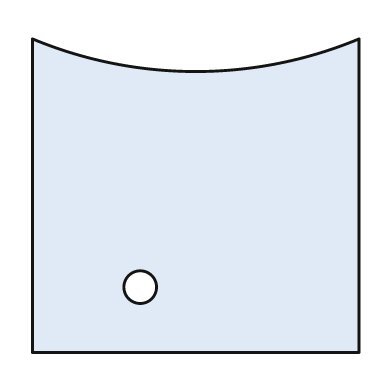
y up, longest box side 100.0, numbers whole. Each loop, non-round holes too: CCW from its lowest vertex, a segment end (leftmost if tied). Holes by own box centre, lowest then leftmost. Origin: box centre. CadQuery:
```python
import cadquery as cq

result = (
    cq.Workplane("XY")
    .moveTo(-50.0, -48.0)
    .lineTo(50.0, -48.0)
    .lineTo(50.0, 48.0)
    .threePointArc((0.0, 38.0), (-50.0, 48.0))
    .close()
    .moveTo(-17.0, -28.0)
    .circle(5.0)
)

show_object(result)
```